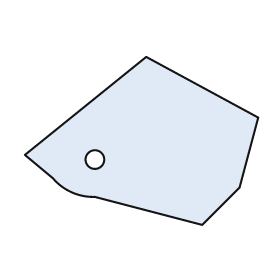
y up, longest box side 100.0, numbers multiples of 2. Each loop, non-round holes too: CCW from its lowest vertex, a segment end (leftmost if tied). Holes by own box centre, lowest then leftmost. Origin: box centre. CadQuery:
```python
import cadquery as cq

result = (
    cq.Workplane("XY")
    .moveTo(26.0, -36.0)
    .lineTo(42.0, -20.0)
    .lineTo(50.0, 10.0)
    .lineTo(2.0, 36.0)
    .lineTo(-50.0, -6.0)
    .lineTo(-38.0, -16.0)
    .threePointArc((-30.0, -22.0), (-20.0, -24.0))
    .close()
    .moveTo(-20.0, -8.0)
    .circle(4.0)
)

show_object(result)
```